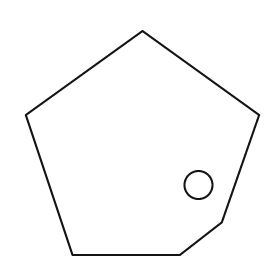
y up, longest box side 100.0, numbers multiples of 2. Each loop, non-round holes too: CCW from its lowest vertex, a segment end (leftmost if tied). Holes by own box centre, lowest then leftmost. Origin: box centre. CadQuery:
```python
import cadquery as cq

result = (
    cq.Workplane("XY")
    .moveTo(-30.0, -48.0)
    .lineTo(16.0, -48.0)
    .lineTo(34.0, -34.0)
    .lineTo(50.0, 12.0)
    .lineTo(0.0, 48.0)
    .lineTo(-50.0, 12.0)
    .close()
    .moveTo(24.0, -18.0)
    .circle(6.0)
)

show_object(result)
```